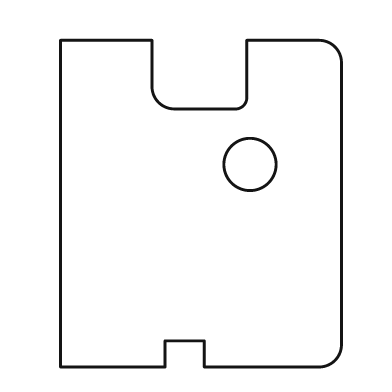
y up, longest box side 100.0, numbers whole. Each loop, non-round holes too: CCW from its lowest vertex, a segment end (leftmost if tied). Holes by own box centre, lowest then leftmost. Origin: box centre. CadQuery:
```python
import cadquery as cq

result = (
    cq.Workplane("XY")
    .moveTo(-43.0, -50.0)
    .lineTo(-11.0, -50.0)
    .lineTo(-11.0, -42.0)
    .lineTo(1.0, -42.0)
    .lineTo(1.0, -50.0)
    .lineTo(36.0, -50.0)
    .threePointArc((41.0, -48.0), (43.0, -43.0))
    .lineTo(43.0, 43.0)
    .threePointArc((41.0, 48.0), (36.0, 50.0))
    .lineTo(14.0, 50.0)
    .lineTo(14.0, 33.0)
    .threePointArc((13.0, 30.0), (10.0, 29.0))
    .lineTo(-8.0, 29.0)
    .threePointArc((-13.0, 31.0), (-15.0, 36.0))
    .lineTo(-15.0, 50.0)
    .lineTo(-43.0, 50.0)
    .close()
    .moveTo(15.0, 12.0)
    .circle(8.0)
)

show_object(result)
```